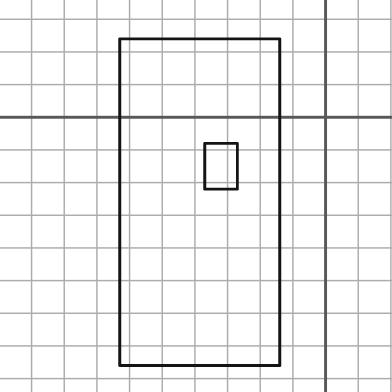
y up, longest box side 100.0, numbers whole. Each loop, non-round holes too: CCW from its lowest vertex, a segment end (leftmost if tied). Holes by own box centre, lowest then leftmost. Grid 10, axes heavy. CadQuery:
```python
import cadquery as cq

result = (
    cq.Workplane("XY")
    .moveTo(-63.0, -76.0)
    .lineTo(-14.0, -76.0)
    .lineTo(-14.0, 24.0)
    .lineTo(-63.0, 24.0)
    .close()
    .moveTo(-37.0, -22.0)
    .lineTo(-27.0, -22.0)
    .lineTo(-27.0, -8.0)
    .lineTo(-37.0, -8.0)
    .close()
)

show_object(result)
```